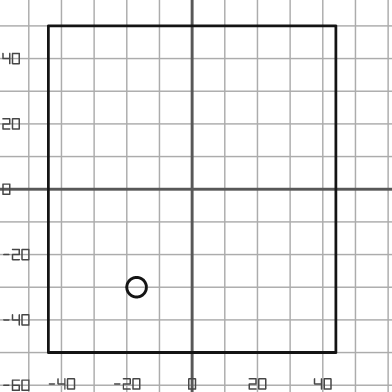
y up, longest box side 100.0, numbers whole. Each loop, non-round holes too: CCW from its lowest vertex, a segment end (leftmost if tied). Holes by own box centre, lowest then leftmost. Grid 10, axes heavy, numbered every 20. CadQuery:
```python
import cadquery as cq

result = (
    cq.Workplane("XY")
    .moveTo(-44.0, -50.0)
    .lineTo(44.0, -50.0)
    .lineTo(44.0, 50.0)
    .lineTo(-44.0, 50.0)
    .close()
    .moveTo(-17.0, -30.0)
    .circle(3.0)
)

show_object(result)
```